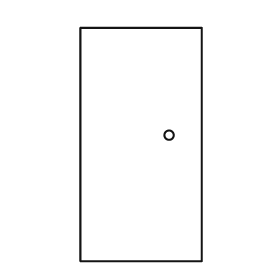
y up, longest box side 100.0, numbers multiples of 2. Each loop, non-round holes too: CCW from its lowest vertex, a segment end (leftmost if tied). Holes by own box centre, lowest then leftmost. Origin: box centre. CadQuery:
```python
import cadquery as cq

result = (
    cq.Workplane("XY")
    .moveTo(-26.0, -50.0)
    .lineTo(26.0, -50.0)
    .lineTo(26.0, 50.0)
    .lineTo(-26.0, 50.0)
    .close()
    .moveTo(12.0, 4.0)
    .circle(2.0)
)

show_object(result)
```